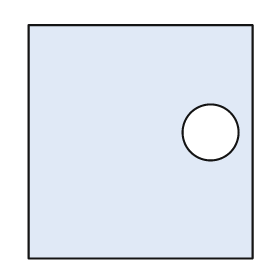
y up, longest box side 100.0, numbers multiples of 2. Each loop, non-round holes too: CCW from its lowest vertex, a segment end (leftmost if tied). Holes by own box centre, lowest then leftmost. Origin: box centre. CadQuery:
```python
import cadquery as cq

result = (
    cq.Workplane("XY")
    .moveTo(-48.0, -50.0)
    .lineTo(48.0, -50.0)
    .lineTo(48.0, 50.0)
    .lineTo(-48.0, 50.0)
    .close()
    .moveTo(30.0, 4.0)
    .circle(12.0)
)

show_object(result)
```